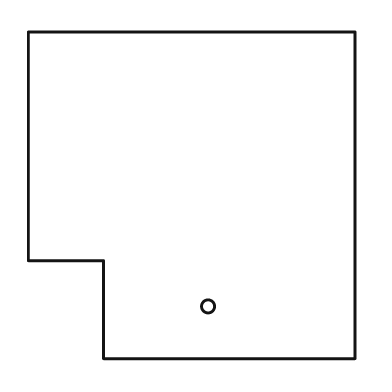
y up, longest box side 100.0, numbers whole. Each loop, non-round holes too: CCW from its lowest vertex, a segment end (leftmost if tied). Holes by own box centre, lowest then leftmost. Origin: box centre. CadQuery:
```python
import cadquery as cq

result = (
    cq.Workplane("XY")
    .moveTo(-27.0, -50.0)
    .lineTo(50.0, -50.0)
    .lineTo(50.0, 50.0)
    .lineTo(-50.0, 50.0)
    .lineTo(-50.0, -20.0)
    .lineTo(-27.0, -20.0)
    .close()
    .moveTo(5.0, -34.0)
    .circle(2.0)
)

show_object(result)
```